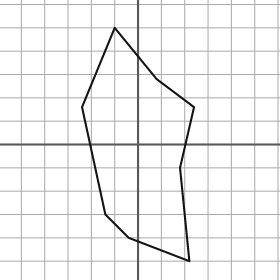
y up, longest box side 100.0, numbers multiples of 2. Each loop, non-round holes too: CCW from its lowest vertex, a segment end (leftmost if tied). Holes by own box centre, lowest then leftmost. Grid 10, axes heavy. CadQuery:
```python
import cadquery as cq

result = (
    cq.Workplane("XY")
    .moveTo(22.0, -50.0)
    .lineTo(18.0, -10.0)
    .lineTo(24.0, 16.0)
    .lineTo(8.0, 28.0)
    .lineTo(-10.0, 50.0)
    .lineTo(-24.0, 16.0)
    .lineTo(-14.0, -30.0)
    .lineTo(-4.0, -40.0)
    .close()
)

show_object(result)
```